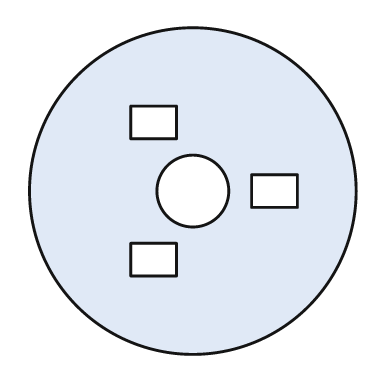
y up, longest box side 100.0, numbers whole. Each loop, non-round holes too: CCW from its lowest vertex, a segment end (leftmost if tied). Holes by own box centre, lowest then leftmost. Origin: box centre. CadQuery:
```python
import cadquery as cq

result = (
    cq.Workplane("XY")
    .moveTo(0.0, 0.0)
    .circle(50.0)
    .moveTo(-19.0, -26.0)
    .lineTo(-5.0, -26.0)
    .lineTo(-5.0, -16.0)
    .lineTo(-19.0, -16.0)
    .close()
    .moveTo(0.0, 0.0)
    .circle(11.0)
    .moveTo(18.0, -5.0)
    .lineTo(32.0, -5.0)
    .lineTo(32.0, 5.0)
    .lineTo(18.0, 5.0)
    .close()
    .moveTo(-19.0, 16.0)
    .lineTo(-5.0, 16.0)
    .lineTo(-5.0, 26.0)
    .lineTo(-19.0, 26.0)
    .close()
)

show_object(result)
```